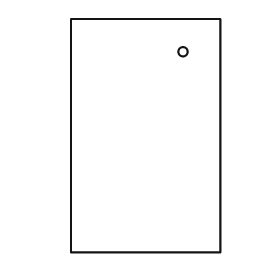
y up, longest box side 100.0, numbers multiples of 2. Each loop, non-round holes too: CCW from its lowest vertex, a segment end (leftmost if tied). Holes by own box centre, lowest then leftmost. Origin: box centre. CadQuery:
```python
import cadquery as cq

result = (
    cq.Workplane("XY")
    .moveTo(-32.0, -50.0)
    .lineTo(32.0, -50.0)
    .lineTo(32.0, 50.0)
    .lineTo(-32.0, 50.0)
    .close()
    .moveTo(16.0, 36.0)
    .circle(2.0)
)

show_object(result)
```